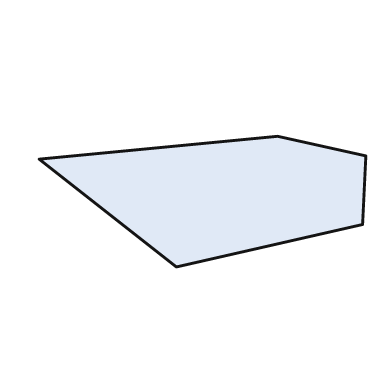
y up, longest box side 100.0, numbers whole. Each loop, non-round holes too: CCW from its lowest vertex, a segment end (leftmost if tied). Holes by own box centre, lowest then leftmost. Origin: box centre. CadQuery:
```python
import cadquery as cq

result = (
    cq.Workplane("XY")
    .moveTo(-8.0, -20.0)
    .lineTo(49.0, -7.0)
    .lineTo(50.0, 14.0)
    .lineTo(23.0, 20.0)
    .lineTo(-50.0, 13.0)
    .close()
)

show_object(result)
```